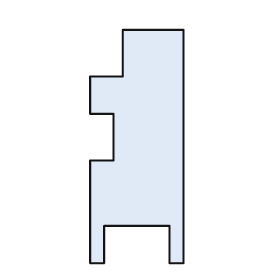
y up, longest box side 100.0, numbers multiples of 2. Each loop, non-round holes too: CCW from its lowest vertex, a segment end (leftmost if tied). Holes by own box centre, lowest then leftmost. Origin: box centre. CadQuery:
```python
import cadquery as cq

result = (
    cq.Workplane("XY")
    .moveTo(-20.0, -50.0)
    .lineTo(-14.0, -50.0)
    .lineTo(-14.0, -34.0)
    .lineTo(14.0, -34.0)
    .lineTo(14.0, -50.0)
    .lineTo(20.0, -50.0)
    .lineTo(20.0, 50.0)
    .lineTo(-6.0, 50.0)
    .lineTo(-6.0, 30.0)
    .lineTo(-20.0, 30.0)
    .lineTo(-20.0, 14.0)
    .lineTo(-10.0, 14.0)
    .lineTo(-10.0, -6.0)
    .lineTo(-20.0, -6.0)
    .close()
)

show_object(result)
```